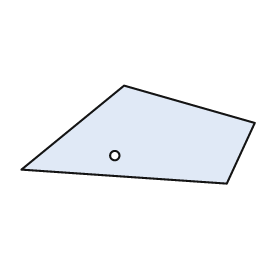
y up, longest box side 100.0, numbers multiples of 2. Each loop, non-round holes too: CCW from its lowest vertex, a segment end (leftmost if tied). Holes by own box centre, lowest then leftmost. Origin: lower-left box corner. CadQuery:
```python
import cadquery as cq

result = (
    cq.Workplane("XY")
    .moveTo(88.0, 0.0)
    .lineTo(100.0, 26.0)
    .lineTo(44.0, 42.0)
    .lineTo(0.0, 6.0)
    .close()
    .moveTo(40.0, 12.0)
    .circle(2.0)
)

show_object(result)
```